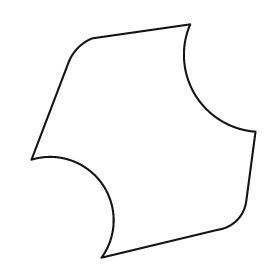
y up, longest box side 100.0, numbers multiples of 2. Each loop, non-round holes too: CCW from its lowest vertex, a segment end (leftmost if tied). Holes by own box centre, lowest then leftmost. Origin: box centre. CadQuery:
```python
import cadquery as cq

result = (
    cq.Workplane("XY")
    .moveTo(-18.0, -50.0)
    .lineTo(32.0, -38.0)
    .threePointArc((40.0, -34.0), (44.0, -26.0))
    .lineTo(48.0, 4.0)
    .threePointArc((22.0, 20.0), (20.0, 50.0))
    .lineTo(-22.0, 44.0)
    .threePointArc((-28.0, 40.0), (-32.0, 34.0))
    .lineTo(-48.0, -8.0)
    .threePointArc((-18.0, -18.0), (-18.0, -50.0))
    .close()
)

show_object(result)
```